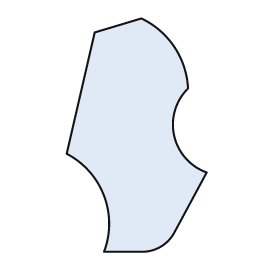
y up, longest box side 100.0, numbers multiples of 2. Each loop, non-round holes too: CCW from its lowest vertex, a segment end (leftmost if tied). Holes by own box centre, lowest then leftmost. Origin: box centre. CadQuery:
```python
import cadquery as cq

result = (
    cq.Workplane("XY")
    .moveTo(-14.0, -50.0)
    .lineTo(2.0, -50.0)
    .threePointArc((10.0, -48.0), (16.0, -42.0))
    .lineTo(30.0, -16.0)
    .threePointArc((16.0, 0.0), (22.0, 20.0))
    .threePointArc((16.0, 38.0), (2.0, 50.0))
    .lineTo(-18.0, 44.0)
    .lineTo(-30.0, -8.0)
    .threePointArc((-14.0, -26.0), (-14.0, -50.0))
    .close()
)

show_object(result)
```